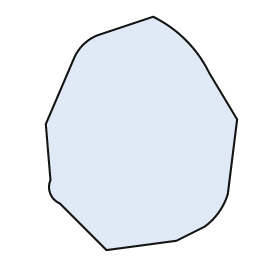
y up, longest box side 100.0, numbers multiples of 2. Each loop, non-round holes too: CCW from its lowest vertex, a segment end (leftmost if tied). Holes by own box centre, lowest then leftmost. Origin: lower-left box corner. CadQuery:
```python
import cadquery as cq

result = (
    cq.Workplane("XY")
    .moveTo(26.0, 0.0)
    .lineTo(56.0, 4.0)
    .lineTo(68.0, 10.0)
    .threePointArc((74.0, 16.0), (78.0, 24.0))
    .lineTo(82.0, 56.0)
    .lineTo(70.0, 76.0)
    .threePointArc((60.0, 90.0), (46.0, 100.0))
    .lineTo(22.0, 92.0)
    .threePointArc((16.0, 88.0), (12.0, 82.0))
    .lineTo(0.0, 54.0)
    .lineTo(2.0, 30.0)
    .threePointArc((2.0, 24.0), (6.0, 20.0))
    .close()
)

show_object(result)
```